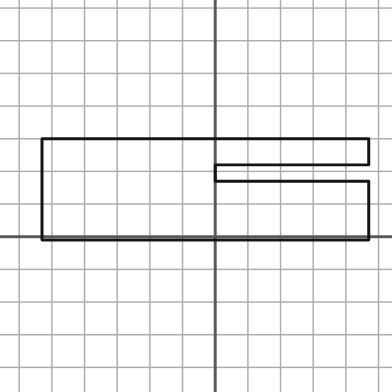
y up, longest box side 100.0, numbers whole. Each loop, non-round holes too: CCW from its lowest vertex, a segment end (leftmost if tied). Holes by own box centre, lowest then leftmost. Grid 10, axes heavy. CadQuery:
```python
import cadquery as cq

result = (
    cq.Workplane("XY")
    .moveTo(-53.0, -1.0)
    .lineTo(47.0, -1.0)
    .lineTo(47.0, 17.0)
    .lineTo(0.0, 17.0)
    .lineTo(0.0, 22.0)
    .lineTo(47.0, 22.0)
    .lineTo(47.0, 30.0)
    .lineTo(-53.0, 30.0)
    .close()
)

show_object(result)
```